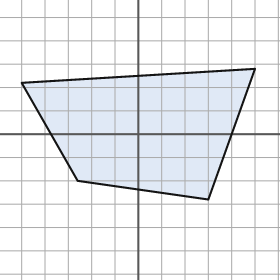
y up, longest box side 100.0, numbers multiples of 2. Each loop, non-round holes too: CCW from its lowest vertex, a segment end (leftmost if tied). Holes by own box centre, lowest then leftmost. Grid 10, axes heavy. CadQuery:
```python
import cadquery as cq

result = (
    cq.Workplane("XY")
    .moveTo(30.0, -28.0)
    .lineTo(50.0, 28.0)
    .lineTo(-50.0, 22.0)
    .lineTo(-26.0, -20.0)
    .close()
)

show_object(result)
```